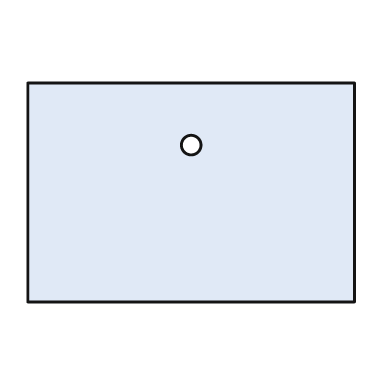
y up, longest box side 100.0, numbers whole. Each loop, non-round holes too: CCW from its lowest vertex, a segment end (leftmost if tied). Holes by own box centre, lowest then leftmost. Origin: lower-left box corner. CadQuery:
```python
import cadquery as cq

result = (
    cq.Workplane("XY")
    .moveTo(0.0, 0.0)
    .lineTo(100.0, 0.0)
    .lineTo(100.0, 67.0)
    .lineTo(0.0, 67.0)
    .close()
    .moveTo(50.0, 48.0)
    .circle(3.0)
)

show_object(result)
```